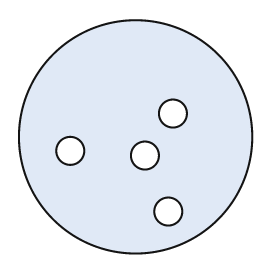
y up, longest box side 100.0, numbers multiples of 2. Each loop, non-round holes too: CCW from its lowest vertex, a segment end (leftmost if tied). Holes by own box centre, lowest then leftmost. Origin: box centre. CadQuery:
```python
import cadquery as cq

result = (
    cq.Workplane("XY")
    .moveTo(0.0, 0.0)
    .circle(50.0)
    .moveTo(14.0, -32.0)
    .circle(6.0)
    .moveTo(4.0, -8.0)
    .circle(6.0)
    .moveTo(-28.0, -6.0)
    .circle(6.0)
    .moveTo(16.0, 10.0)
    .circle(6.0)
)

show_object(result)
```